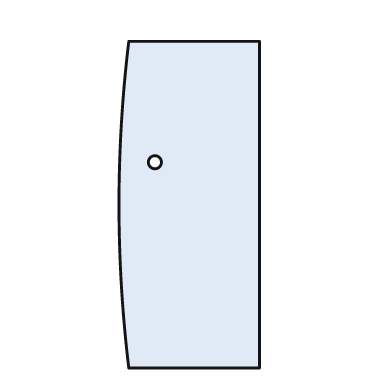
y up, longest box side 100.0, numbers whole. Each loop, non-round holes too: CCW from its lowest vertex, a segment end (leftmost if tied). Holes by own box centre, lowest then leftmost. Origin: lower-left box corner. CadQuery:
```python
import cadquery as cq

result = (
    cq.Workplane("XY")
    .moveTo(3.0, 0.0)
    .lineTo(43.0, 0.0)
    .lineTo(43.0, 100.0)
    .lineTo(3.0, 100.0)
    .threePointArc((0.0, 50.0), (3.0, 0.0))
    .close()
    .moveTo(11.0, 63.0)
    .circle(2.0)
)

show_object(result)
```